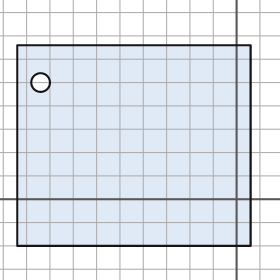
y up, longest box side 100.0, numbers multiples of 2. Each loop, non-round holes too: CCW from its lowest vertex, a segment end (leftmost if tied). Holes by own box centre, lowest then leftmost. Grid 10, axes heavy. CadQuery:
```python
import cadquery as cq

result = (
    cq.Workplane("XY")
    .moveTo(-94.0, -20.0)
    .lineTo(6.0, -20.0)
    .lineTo(6.0, 66.0)
    .lineTo(-94.0, 66.0)
    .close()
    .moveTo(-84.0, 50.0)
    .circle(4.0)
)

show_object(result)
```